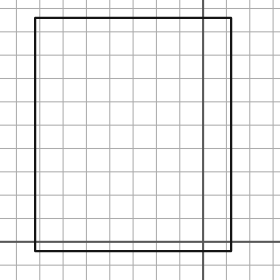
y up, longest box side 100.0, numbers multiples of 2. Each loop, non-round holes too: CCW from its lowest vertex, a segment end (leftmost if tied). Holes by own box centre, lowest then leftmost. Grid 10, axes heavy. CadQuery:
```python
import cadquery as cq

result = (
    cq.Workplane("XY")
    .moveTo(-72.0, -4.0)
    .lineTo(12.0, -4.0)
    .lineTo(12.0, 96.0)
    .lineTo(-72.0, 96.0)
    .close()
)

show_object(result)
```